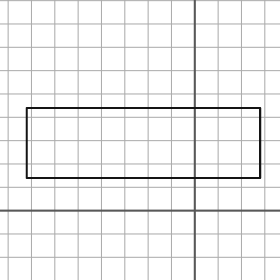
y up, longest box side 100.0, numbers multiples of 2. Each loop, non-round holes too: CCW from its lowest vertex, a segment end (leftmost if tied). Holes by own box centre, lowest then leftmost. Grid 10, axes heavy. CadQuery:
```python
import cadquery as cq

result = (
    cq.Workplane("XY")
    .moveTo(-72.0, 14.0)
    .lineTo(28.0, 14.0)
    .lineTo(28.0, 44.0)
    .lineTo(-72.0, 44.0)
    .close()
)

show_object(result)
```